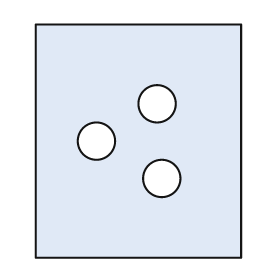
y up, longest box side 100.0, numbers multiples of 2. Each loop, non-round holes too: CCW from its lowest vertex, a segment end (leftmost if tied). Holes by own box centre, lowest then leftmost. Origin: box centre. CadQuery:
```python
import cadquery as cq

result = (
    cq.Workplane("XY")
    .moveTo(-44.0, -50.0)
    .lineTo(44.0, -50.0)
    .lineTo(44.0, 50.0)
    .lineTo(-44.0, 50.0)
    .close()
    .moveTo(10.0, -16.0)
    .circle(8.0)
    .moveTo(-18.0, 0.0)
    .circle(8.0)
    .moveTo(8.0, 16.0)
    .circle(8.0)
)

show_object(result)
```